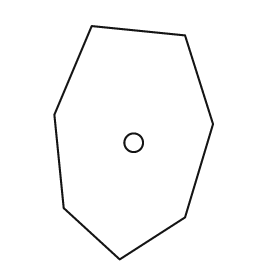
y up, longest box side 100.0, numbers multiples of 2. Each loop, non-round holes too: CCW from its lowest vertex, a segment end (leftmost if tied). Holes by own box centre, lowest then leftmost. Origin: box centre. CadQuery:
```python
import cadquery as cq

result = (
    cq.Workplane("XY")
    .moveTo(-6.0, -50.0)
    .lineTo(22.0, -32.0)
    .lineTo(34.0, 8.0)
    .lineTo(22.0, 46.0)
    .lineTo(-18.0, 50.0)
    .lineTo(-34.0, 12.0)
    .lineTo(-30.0, -28.0)
    .close()
    .moveTo(0.0, 0.0)
    .circle(4.0)
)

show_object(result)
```